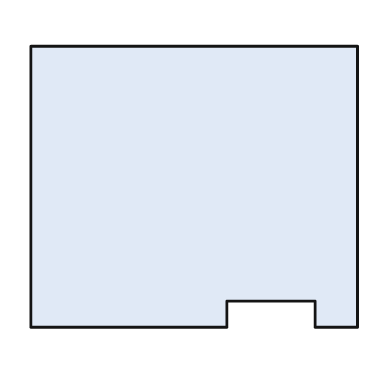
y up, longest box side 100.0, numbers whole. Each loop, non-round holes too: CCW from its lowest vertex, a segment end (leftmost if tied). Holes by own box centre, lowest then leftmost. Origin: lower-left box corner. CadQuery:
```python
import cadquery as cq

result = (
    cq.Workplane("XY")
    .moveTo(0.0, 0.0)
    .lineTo(60.0, 0.0)
    .lineTo(60.0, 8.0)
    .lineTo(87.0, 8.0)
    .lineTo(87.0, 0.0)
    .lineTo(100.0, 0.0)
    .lineTo(100.0, 86.0)
    .lineTo(0.0, 86.0)
    .close()
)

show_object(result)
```